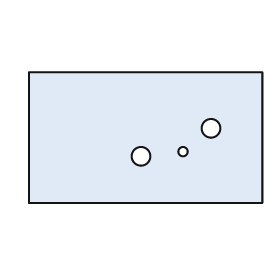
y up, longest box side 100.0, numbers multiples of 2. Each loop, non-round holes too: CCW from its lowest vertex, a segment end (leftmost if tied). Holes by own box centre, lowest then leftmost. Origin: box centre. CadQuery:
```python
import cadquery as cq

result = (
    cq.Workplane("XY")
    .moveTo(-50.0, -28.0)
    .lineTo(50.0, -28.0)
    .lineTo(50.0, 28.0)
    .lineTo(-50.0, 28.0)
    .close()
    .moveTo(-2.0, -8.0)
    .circle(4.0)
    .moveTo(16.0, -6.0)
    .circle(2.0)
    .moveTo(28.0, 4.0)
    .circle(4.0)
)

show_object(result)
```